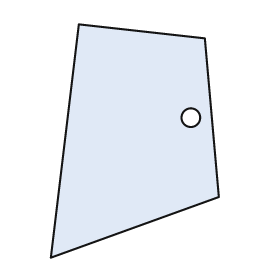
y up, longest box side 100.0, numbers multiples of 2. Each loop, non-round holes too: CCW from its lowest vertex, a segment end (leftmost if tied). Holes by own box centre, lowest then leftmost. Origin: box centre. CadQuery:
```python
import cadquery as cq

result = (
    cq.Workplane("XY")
    .moveTo(-36.0, -50.0)
    .lineTo(36.0, -24.0)
    .lineTo(30.0, 44.0)
    .lineTo(-24.0, 50.0)
    .close()
    .moveTo(24.0, 10.0)
    .circle(4.0)
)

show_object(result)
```